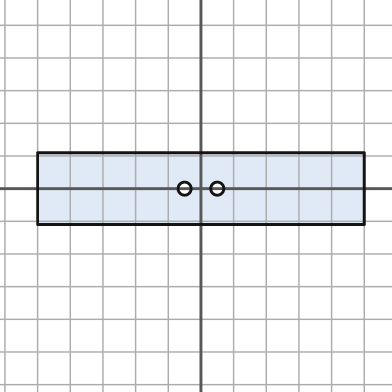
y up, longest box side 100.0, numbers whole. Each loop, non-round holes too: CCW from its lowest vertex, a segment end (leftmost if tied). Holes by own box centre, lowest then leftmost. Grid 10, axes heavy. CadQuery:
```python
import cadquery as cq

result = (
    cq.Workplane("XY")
    .moveTo(-50.0, -11.0)
    .lineTo(50.0, -11.0)
    .lineTo(50.0, 11.0)
    .lineTo(-50.0, 11.0)
    .close()
    .moveTo(-5.0, 0.0)
    .circle(2.0)
    .moveTo(5.0, 0.0)
    .circle(2.0)
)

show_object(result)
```